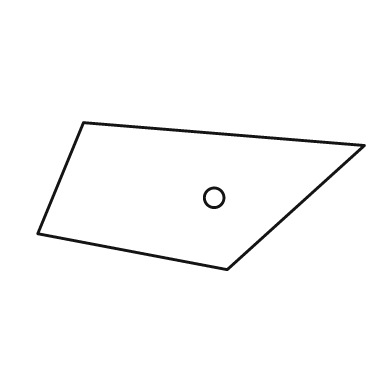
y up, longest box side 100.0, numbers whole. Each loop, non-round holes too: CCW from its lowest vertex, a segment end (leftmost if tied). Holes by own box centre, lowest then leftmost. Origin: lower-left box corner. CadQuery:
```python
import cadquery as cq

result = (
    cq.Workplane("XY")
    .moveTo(58.0, 0.0)
    .lineTo(100.0, 38.0)
    .lineTo(14.0, 45.0)
    .lineTo(0.0, 11.0)
    .close()
    .moveTo(54.0, 22.0)
    .circle(3.0)
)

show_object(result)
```